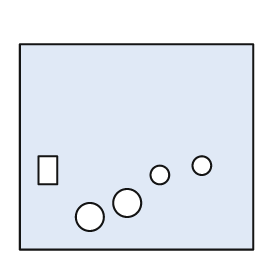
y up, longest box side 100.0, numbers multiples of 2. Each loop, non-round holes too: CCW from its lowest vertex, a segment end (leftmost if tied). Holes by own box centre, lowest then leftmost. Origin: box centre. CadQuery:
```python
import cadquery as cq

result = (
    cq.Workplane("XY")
    .moveTo(-50.0, -44.0)
    .lineTo(50.0, -44.0)
    .lineTo(50.0, 44.0)
    .lineTo(-50.0, 44.0)
    .close()
    .moveTo(-20.0, -30.0)
    .circle(6.0)
    .moveTo(-4.0, -24.0)
    .circle(6.0)
    .moveTo(10.0, -12.0)
    .circle(4.0)
    .moveTo(-42.0, -16.0)
    .lineTo(-34.0, -16.0)
    .lineTo(-34.0, -4.0)
    .lineTo(-42.0, -4.0)
    .close()
    .moveTo(28.0, -8.0)
    .circle(4.0)
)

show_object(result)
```